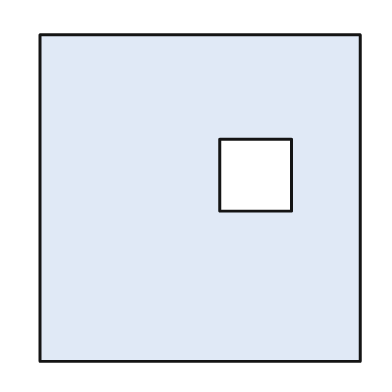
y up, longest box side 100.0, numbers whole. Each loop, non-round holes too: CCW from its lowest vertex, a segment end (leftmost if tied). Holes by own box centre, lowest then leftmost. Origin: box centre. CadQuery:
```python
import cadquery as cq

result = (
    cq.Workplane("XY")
    .moveTo(-49.0, -50.0)
    .lineTo(49.0, -50.0)
    .lineTo(49.0, 50.0)
    .lineTo(-49.0, 50.0)
    .close()
    .moveTo(6.0, -4.0)
    .lineTo(28.0, -4.0)
    .lineTo(28.0, 18.0)
    .lineTo(6.0, 18.0)
    .close()
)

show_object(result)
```